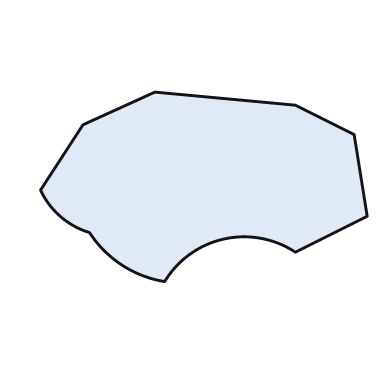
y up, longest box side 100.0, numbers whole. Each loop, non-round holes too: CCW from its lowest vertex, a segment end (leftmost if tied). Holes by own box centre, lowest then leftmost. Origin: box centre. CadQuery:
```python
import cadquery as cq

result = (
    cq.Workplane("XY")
    .moveTo(-12.0, -29.0)
    .threePointArc((6.0, -16.0), (28.0, -20.0))
    .lineTo(50.0, -9.0)
    .lineTo(46.0, 16.0)
    .lineTo(28.0, 25.0)
    .lineTo(-15.0, 29.0)
    .lineTo(-37.0, 19.0)
    .lineTo(-50.0, -1.0)
    .threePointArc((-44.0, -9.0), (-35.0, -14.0))
    .threePointArc((-25.0, -24.0), (-12.0, -29.0))
    .close()
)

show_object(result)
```